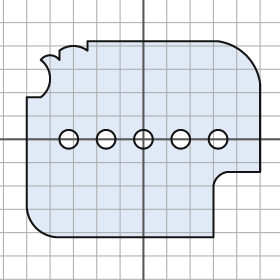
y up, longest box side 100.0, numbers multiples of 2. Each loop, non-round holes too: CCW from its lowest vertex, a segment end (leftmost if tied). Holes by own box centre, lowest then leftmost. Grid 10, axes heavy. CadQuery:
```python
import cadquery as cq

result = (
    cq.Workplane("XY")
    .moveTo(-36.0, -42.0)
    .lineTo(30.0, -42.0)
    .lineTo(30.0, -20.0)
    .threePointArc((32.0, -16.0), (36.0, -14.0))
    .lineTo(50.0, -14.0)
    .lineTo(50.0, 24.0)
    .threePointArc((44.0, 36.0), (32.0, 42.0))
    .lineTo(-24.0, 42.0)
    .lineTo(-24.0, 38.0)
    .threePointArc((-30.0, 40.0), (-36.0, 38.0))
    .lineTo(-36.0, 34.0)
    .threePointArc((-40.0, 36.0), (-44.0, 34.0))
    .threePointArc((-40.0, 26.0), (-44.0, 18.0))
    .lineTo(-50.0, 18.0)
    .lineTo(-50.0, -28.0)
    .threePointArc((-46.0, -38.0), (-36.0, -42.0))
    .close()
    .moveTo(-32.0, 0.0)
    .circle(4.0)
    .moveTo(-16.0, 0.0)
    .circle(4.0)
    .moveTo(0.0, 0.0)
    .circle(4.0)
    .moveTo(16.0, 0.0)
    .circle(4.0)
    .moveTo(32.0, 0.0)
    .circle(4.0)
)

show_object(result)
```